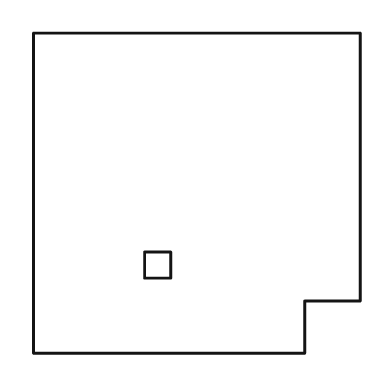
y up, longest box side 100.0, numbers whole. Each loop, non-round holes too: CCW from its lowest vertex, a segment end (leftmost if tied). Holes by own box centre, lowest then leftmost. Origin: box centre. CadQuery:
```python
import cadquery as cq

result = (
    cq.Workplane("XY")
    .moveTo(-50.0, -49.0)
    .lineTo(33.0, -49.0)
    .lineTo(33.0, -33.0)
    .lineTo(50.0, -33.0)
    .lineTo(50.0, 49.0)
    .lineTo(-50.0, 49.0)
    .close()
    .moveTo(-16.0, -26.0)
    .lineTo(-8.0, -26.0)
    .lineTo(-8.0, -18.0)
    .lineTo(-16.0, -18.0)
    .close()
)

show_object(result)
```